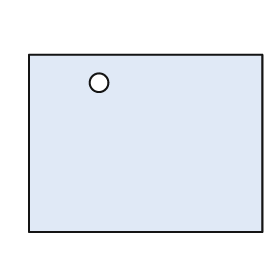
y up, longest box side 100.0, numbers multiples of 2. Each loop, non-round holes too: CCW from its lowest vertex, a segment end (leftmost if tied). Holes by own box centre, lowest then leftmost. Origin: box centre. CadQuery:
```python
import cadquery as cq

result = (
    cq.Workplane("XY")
    .moveTo(-50.0, -38.0)
    .lineTo(50.0, -38.0)
    .lineTo(50.0, 38.0)
    .lineTo(-50.0, 38.0)
    .close()
    .moveTo(-20.0, 26.0)
    .circle(4.0)
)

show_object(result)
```